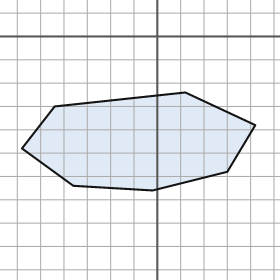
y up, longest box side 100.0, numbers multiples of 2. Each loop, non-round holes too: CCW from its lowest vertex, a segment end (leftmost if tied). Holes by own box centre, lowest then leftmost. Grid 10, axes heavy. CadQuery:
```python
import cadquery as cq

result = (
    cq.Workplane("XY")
    .moveTo(-2.0, -66.0)
    .lineTo(30.0, -58.0)
    .lineTo(42.0, -38.0)
    .lineTo(12.0, -24.0)
    .lineTo(-44.0, -30.0)
    .lineTo(-58.0, -48.0)
    .lineTo(-36.0, -64.0)
    .close()
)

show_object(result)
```